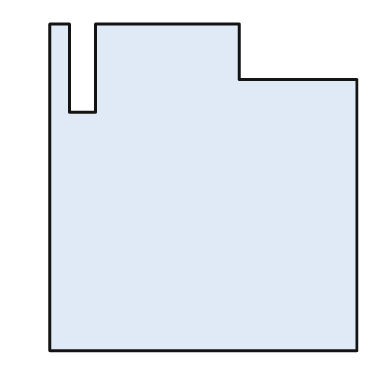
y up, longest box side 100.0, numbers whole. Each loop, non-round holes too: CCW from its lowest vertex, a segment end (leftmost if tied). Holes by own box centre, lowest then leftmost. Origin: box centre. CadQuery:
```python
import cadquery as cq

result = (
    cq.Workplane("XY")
    .moveTo(-47.0, -50.0)
    .lineTo(47.0, -50.0)
    .lineTo(47.0, 33.0)
    .lineTo(11.0, 33.0)
    .lineTo(11.0, 50.0)
    .lineTo(-33.0, 50.0)
    .lineTo(-33.0, 23.0)
    .lineTo(-41.0, 23.0)
    .lineTo(-41.0, 50.0)
    .lineTo(-47.0, 50.0)
    .close()
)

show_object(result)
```